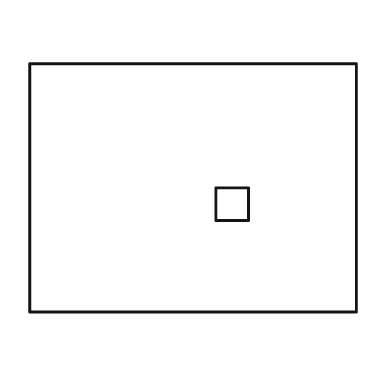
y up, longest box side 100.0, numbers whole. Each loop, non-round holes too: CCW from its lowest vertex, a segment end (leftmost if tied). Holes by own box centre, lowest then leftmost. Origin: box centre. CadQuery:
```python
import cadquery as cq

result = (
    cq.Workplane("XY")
    .moveTo(-50.0, -38.0)
    .lineTo(50.0, -38.0)
    .lineTo(50.0, 38.0)
    .lineTo(-50.0, 38.0)
    .close()
    .moveTo(7.0, -10.0)
    .lineTo(17.0, -10.0)
    .lineTo(17.0, 0.0)
    .lineTo(7.0, 0.0)
    .close()
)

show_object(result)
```